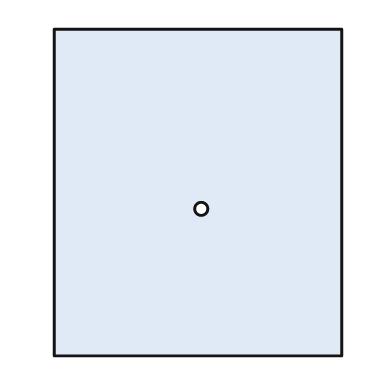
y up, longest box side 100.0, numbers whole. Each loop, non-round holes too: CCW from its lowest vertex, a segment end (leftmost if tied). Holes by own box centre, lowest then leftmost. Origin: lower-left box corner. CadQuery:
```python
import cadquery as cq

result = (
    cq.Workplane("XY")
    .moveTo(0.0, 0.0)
    .lineTo(88.0, 0.0)
    .lineTo(88.0, 100.0)
    .lineTo(0.0, 100.0)
    .close()
    .moveTo(45.0, 45.0)
    .circle(2.0)
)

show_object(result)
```